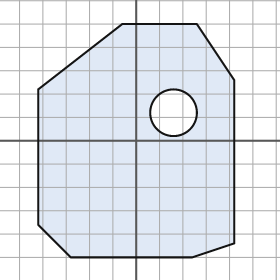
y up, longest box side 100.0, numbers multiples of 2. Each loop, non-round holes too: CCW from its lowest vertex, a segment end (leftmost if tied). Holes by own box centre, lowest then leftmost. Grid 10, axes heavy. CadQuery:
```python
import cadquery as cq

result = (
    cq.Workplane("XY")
    .moveTo(-28.0, -50.0)
    .lineTo(24.0, -50.0)
    .lineTo(42.0, -44.0)
    .lineTo(42.0, 26.0)
    .lineTo(26.0, 50.0)
    .lineTo(-6.0, 50.0)
    .lineTo(-42.0, 22.0)
    .lineTo(-42.0, -36.0)
    .close()
    .moveTo(16.0, 12.0)
    .circle(10.0)
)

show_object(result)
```